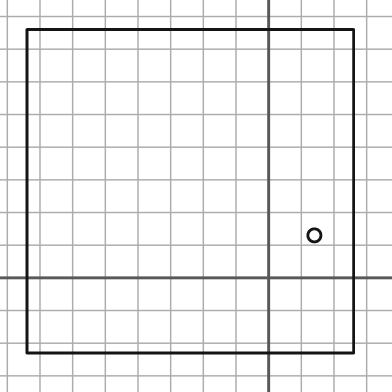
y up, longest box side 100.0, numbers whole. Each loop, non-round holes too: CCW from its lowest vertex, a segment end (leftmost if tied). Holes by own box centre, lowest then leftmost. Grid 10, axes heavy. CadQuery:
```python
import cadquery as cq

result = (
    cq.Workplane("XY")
    .moveTo(-74.0, -23.0)
    .lineTo(26.0, -23.0)
    .lineTo(26.0, 76.0)
    .lineTo(-74.0, 76.0)
    .close()
    .moveTo(14.0, 13.0)
    .circle(2.0)
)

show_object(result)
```